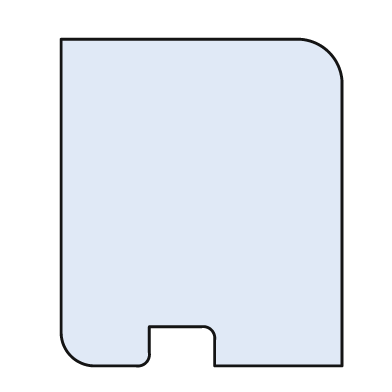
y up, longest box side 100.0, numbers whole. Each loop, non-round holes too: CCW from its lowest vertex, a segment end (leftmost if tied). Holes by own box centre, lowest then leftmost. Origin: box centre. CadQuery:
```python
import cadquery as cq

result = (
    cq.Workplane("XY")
    .moveTo(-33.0, -50.0)
    .lineTo(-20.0, -50.0)
    .threePointArc((-17.0, -49.0), (-16.0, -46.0))
    .lineTo(-16.0, -38.0)
    .lineTo(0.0, -38.0)
    .threePointArc((3.0, -39.0), (4.0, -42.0))
    .lineTo(4.0, -50.0)
    .lineTo(43.0, -50.0)
    .lineTo(43.0, 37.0)
    .threePointArc((39.0, 46.0), (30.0, 50.0))
    .lineTo(-43.0, 50.0)
    .lineTo(-43.0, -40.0)
    .threePointArc((-40.0, -47.0), (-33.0, -50.0))
    .close()
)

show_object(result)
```